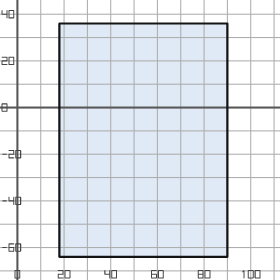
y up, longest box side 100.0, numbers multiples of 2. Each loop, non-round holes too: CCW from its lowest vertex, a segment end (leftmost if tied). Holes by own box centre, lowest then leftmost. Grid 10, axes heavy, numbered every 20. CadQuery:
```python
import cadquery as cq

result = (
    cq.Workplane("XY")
    .moveTo(18.0, -64.0)
    .lineTo(90.0, -64.0)
    .lineTo(90.0, 36.0)
    .lineTo(18.0, 36.0)
    .close()
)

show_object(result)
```